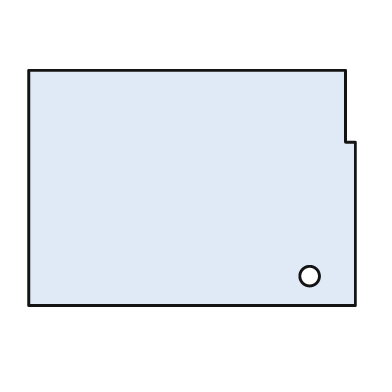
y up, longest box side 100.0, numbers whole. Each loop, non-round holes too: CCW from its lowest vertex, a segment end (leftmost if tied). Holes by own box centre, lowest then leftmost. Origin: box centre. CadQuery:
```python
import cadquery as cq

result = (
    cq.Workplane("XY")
    .moveTo(-50.0, -36.0)
    .lineTo(50.0, -36.0)
    .lineTo(50.0, 14.0)
    .lineTo(47.0, 14.0)
    .lineTo(47.0, 36.0)
    .lineTo(-50.0, 36.0)
    .close()
    .moveTo(36.0, -27.0)
    .circle(3.0)
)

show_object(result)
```